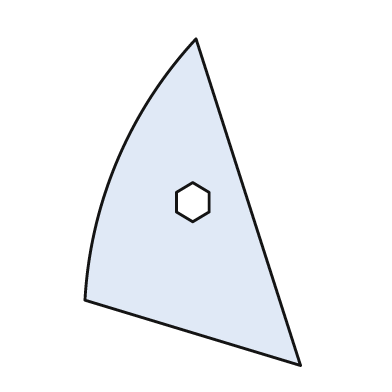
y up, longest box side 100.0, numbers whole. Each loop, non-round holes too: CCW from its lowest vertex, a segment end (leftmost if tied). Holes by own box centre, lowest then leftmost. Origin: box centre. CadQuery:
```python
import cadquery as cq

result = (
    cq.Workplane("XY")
    .moveTo(33.0, -50.0)
    .lineTo(1.0, 50.0)
    .threePointArc((-23.0, 13.0), (-33.0, -30.0))
    .close()
    .moveTo(0.0, -6.0)
    .lineTo(5.0, -3.0)
    .lineTo(5.0, 3.0)
    .lineTo(0.0, 6.0)
    .lineTo(-5.0, 3.0)
    .lineTo(-5.0, -3.0)
    .close()
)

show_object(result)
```